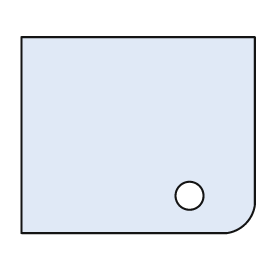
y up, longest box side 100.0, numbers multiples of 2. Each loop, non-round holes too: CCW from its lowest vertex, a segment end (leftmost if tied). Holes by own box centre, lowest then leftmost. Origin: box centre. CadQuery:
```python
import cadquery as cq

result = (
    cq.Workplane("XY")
    .moveTo(-50.0, -42.0)
    .lineTo(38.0, -42.0)
    .threePointArc((46.0, -38.0), (50.0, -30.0))
    .lineTo(50.0, 42.0)
    .lineTo(-50.0, 42.0)
    .close()
    .moveTo(22.0, -26.0)
    .circle(6.0)
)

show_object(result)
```